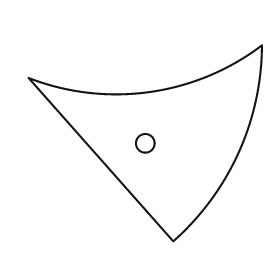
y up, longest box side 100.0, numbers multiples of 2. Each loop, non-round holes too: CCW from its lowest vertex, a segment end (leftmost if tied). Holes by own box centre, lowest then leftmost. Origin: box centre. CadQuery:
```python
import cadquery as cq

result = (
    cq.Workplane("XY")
    .moveTo(12.0, -42.0)
    .threePointArc((40.0, -4.0), (50.0, 42.0))
    .threePointArc((2.0, 22.0), (-50.0, 28.0))
    .close()
    .moveTo(0.0, 0.0)
    .circle(4.0)
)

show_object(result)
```